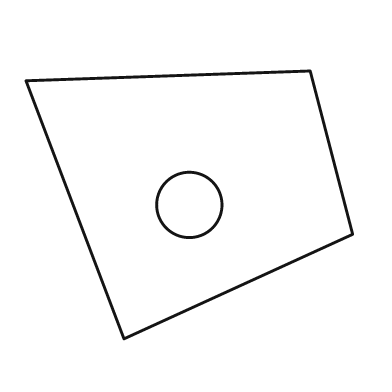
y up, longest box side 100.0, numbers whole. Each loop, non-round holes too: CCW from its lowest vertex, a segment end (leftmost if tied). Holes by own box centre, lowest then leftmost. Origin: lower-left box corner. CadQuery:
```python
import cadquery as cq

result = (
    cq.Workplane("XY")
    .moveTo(30.0, 0.0)
    .lineTo(100.0, 32.0)
    .lineTo(87.0, 82.0)
    .lineTo(0.0, 79.0)
    .close()
    .moveTo(50.0, 41.0)
    .circle(10.0)
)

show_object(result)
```